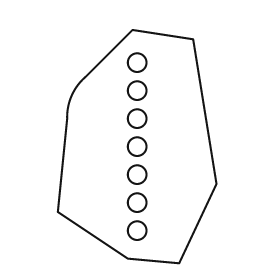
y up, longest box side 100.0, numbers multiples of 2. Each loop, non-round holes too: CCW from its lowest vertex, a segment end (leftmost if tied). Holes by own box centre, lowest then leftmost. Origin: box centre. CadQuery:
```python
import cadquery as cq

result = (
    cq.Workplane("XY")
    .moveTo(18.0, -50.0)
    .lineTo(34.0, -16.0)
    .lineTo(24.0, 46.0)
    .lineTo(-2.0, 50.0)
    .lineTo(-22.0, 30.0)
    .threePointArc((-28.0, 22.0), (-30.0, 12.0))
    .lineTo(-34.0, -28.0)
    .lineTo(-4.0, -48.0)
    .close()
    .moveTo(0.0, -36.0)
    .circle(4.0)
    .moveTo(0.0, -24.0)
    .circle(4.0)
    .moveTo(0.0, -12.0)
    .circle(4.0)
    .moveTo(0.0, 0.0)
    .circle(4.0)
    .moveTo(0.0, 12.0)
    .circle(4.0)
    .moveTo(0.0, 24.0)
    .circle(4.0)
    .moveTo(0.0, 36.0)
    .circle(4.0)
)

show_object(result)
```